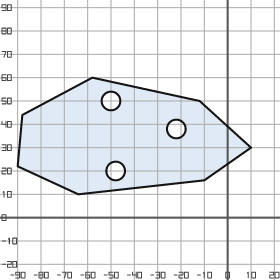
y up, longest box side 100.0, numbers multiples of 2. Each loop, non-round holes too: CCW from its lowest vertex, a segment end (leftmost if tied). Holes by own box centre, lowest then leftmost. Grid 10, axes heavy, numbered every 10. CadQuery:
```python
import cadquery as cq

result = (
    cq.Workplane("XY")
    .moveTo(-64.0, 10.0)
    .lineTo(-10.0, 16.0)
    .lineTo(10.0, 30.0)
    .lineTo(-12.0, 50.0)
    .lineTo(-58.0, 60.0)
    .lineTo(-88.0, 44.0)
    .lineTo(-90.0, 22.0)
    .close()
    .moveTo(-48.0, 20.0)
    .circle(4.0)
    .moveTo(-22.0, 38.0)
    .circle(4.0)
    .moveTo(-50.0, 50.0)
    .circle(4.0)
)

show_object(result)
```